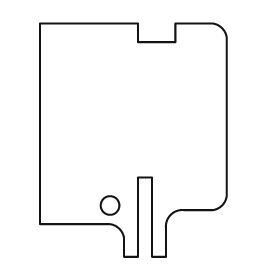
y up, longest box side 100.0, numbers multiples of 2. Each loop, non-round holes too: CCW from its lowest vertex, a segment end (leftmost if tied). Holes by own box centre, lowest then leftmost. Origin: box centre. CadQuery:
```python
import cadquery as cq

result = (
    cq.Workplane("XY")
    .moveTo(-4.0, -50.0)
    .lineTo(2.0, -50.0)
    .lineTo(2.0, -16.0)
    .lineTo(8.0, -16.0)
    .lineTo(8.0, -50.0)
    .lineTo(14.0, -50.0)
    .lineTo(14.0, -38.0)
    .threePointArc((16.0, -32.0), (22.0, -30.0))
    .lineTo(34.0, -30.0)
    .threePointArc((38.0, -28.0), (40.0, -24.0))
    .lineTo(40.0, 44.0)
    .threePointArc((38.0, 48.0), (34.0, 50.0))
    .lineTo(18.0, 50.0)
    .lineTo(18.0, 42.0)
    .lineTo(2.0, 42.0)
    .lineTo(2.0, 50.0)
    .lineTo(-40.0, 50.0)
    .lineTo(-40.0, -36.0)
    .lineTo(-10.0, -36.0)
    .threePointArc((-6.0, -38.0), (-4.0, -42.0))
    .close()
    .moveTo(-10.0, -28.0)
    .circle(4.0)
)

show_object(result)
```